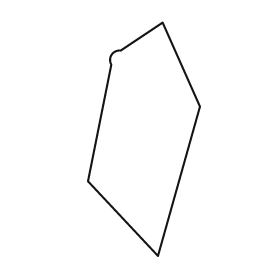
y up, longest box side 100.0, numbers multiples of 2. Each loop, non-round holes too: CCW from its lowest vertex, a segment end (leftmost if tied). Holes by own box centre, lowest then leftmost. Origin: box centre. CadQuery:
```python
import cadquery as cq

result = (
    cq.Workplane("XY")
    .moveTo(6.0, -50.0)
    .lineTo(24.0, 14.0)
    .lineTo(8.0, 50.0)
    .lineTo(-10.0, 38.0)
    .threePointArc((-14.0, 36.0), (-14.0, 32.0))
    .lineTo(-24.0, -18.0)
    .close()
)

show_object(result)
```